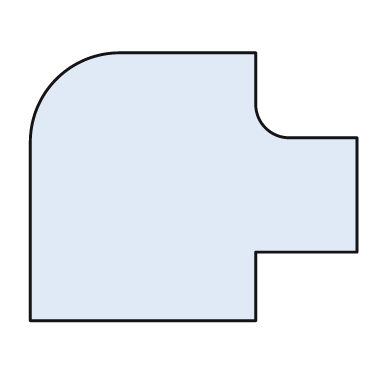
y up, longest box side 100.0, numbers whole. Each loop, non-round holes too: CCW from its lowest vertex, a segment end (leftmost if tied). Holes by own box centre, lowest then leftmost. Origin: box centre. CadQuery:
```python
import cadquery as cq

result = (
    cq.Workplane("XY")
    .moveTo(-50.0, -41.0)
    .lineTo(19.0, -41.0)
    .lineTo(19.0, -20.0)
    .lineTo(50.0, -20.0)
    .lineTo(50.0, 15.0)
    .lineTo(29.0, 15.0)
    .threePointArc((22.0, 18.0), (19.0, 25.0))
    .lineTo(19.0, 41.0)
    .lineTo(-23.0, 41.0)
    .threePointArc((-42.0, 33.0), (-50.0, 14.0))
    .close()
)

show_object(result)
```